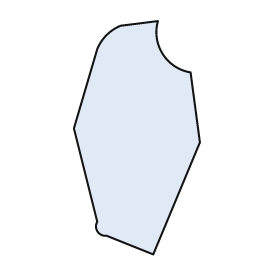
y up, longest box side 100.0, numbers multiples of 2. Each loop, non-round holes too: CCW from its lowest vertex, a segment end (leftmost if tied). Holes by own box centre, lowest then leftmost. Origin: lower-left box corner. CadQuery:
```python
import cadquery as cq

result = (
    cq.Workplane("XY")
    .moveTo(34.0, 0.0)
    .lineTo(54.0, 48.0)
    .lineTo(50.0, 78.0)
    .threePointArc((38.0, 86.0), (36.0, 100.0))
    .lineTo(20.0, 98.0)
    .threePointArc((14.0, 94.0), (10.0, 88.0))
    .lineTo(0.0, 54.0)
    .lineTo(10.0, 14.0)
    .threePointArc((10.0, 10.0), (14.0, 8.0))
    .close()
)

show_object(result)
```